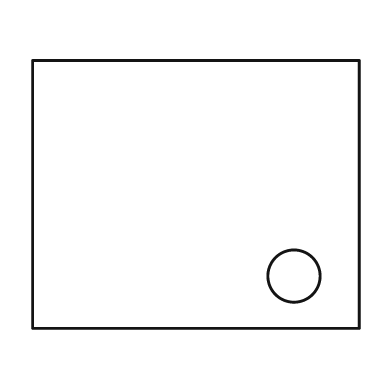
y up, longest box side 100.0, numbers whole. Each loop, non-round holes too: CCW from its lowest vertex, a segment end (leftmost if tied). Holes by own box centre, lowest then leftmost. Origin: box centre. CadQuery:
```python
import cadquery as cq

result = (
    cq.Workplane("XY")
    .moveTo(-50.0, -41.0)
    .lineTo(50.0, -41.0)
    .lineTo(50.0, 41.0)
    .lineTo(-50.0, 41.0)
    .close()
    .moveTo(30.0, -25.0)
    .circle(8.0)
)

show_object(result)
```